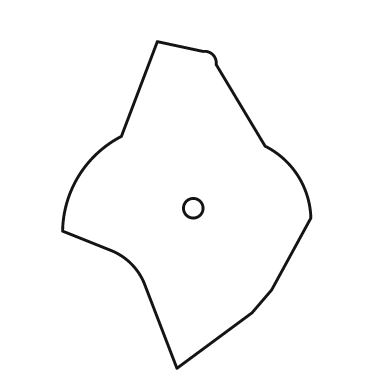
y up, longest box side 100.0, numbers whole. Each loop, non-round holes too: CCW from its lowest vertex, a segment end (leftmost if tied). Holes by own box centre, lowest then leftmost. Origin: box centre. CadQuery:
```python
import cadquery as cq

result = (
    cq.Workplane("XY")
    .moveTo(-3.0, -50.0)
    .lineTo(20.0, -33.0)
    .lineTo(26.0, -26.0)
    .lineTo(38.0, -4.0)
    .threePointArc((34.0, 9.0), (24.0, 18.0))
    .lineTo(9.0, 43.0)
    .threePointArc((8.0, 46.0), (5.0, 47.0))
    .lineTo(-9.0, 50.0)
    .lineTo(-20.0, 21.0)
    .threePointArc((-33.0, 9.0), (-38.0, -8.0))
    .lineTo(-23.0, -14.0)
    .threePointArc((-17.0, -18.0), (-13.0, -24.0))
    .close()
    .moveTo(2.0, -1.0)
    .circle(3.0)
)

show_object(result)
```